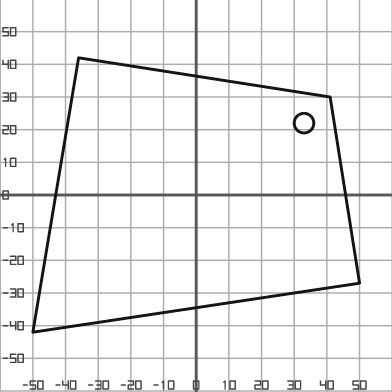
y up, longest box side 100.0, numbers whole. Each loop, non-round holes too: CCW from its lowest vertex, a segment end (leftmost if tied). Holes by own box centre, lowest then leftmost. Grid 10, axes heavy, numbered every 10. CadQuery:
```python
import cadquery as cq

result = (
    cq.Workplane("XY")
    .moveTo(-50.0, -42.0)
    .lineTo(50.0, -27.0)
    .lineTo(41.0, 30.0)
    .lineTo(-36.0, 42.0)
    .close()
    .moveTo(33.0, 22.0)
    .circle(3.0)
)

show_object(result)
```